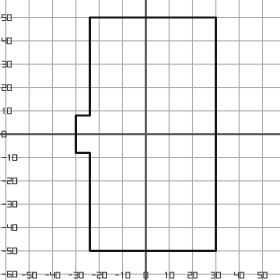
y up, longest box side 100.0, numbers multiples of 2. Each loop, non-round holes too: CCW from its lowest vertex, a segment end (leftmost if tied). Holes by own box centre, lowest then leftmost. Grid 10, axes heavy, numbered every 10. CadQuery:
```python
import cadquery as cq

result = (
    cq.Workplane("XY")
    .moveTo(-24.0, -50.0)
    .lineTo(30.0, -50.0)
    .lineTo(30.0, 50.0)
    .lineTo(-24.0, 50.0)
    .lineTo(-24.0, 8.0)
    .lineTo(-30.0, 8.0)
    .lineTo(-30.0, -8.0)
    .lineTo(-24.0, -8.0)
    .close()
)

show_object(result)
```